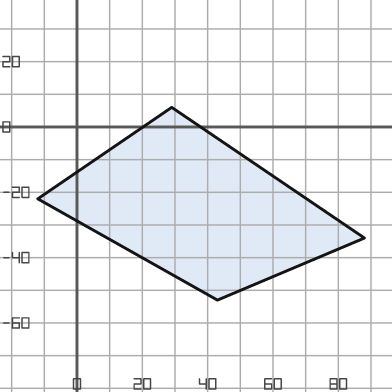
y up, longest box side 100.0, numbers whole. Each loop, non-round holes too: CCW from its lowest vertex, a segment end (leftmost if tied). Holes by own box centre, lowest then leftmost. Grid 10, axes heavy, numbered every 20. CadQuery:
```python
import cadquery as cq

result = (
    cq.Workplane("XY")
    .moveTo(43.0, -53.0)
    .lineTo(88.0, -34.0)
    .lineTo(29.0, 6.0)
    .lineTo(-12.0, -22.0)
    .close()
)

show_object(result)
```